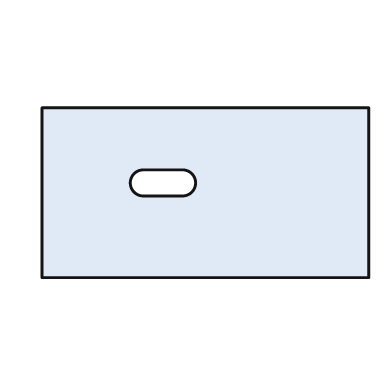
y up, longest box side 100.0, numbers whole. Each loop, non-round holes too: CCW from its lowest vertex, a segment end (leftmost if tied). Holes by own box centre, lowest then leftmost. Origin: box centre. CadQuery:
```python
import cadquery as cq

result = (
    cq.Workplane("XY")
    .moveTo(-50.0, -26.0)
    .lineTo(50.0, -26.0)
    .lineTo(50.0, 26.0)
    .lineTo(-50.0, 26.0)
    .close()
    .moveTo(-19.0, -1.0)
    .lineTo(-7.0, -1.0)
    .threePointArc((-3.0, 3.0), (-7.0, 7.0))
    .lineTo(-19.0, 7.0)
    .threePointArc((-23.0, 3.0), (-19.0, -1.0))
    .close()
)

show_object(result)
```